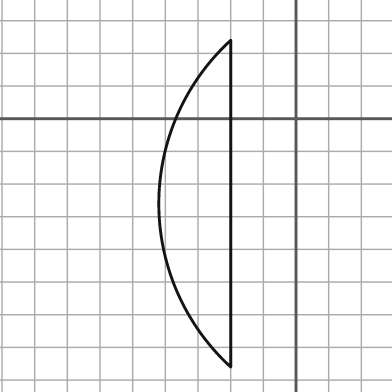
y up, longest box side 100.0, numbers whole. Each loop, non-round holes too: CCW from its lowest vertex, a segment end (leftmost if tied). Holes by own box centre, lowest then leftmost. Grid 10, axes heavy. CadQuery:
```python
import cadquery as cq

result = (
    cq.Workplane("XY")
    .moveTo(-20.0, -76.0)
    .lineTo(-20.0, 24.0)
    .threePointArc((-42.0, -26.0), (-20.0, -76.0))
    .close()
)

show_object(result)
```